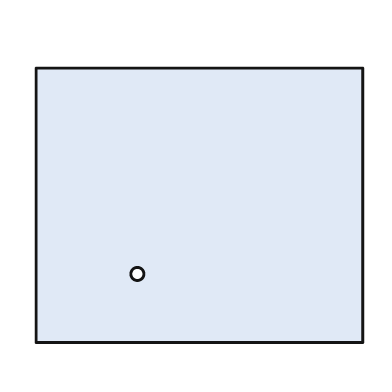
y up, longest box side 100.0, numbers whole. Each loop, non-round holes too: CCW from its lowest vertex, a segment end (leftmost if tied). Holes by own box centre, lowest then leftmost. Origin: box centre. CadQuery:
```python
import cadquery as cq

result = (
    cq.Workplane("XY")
    .moveTo(-50.0, -42.0)
    .lineTo(50.0, -42.0)
    .lineTo(50.0, 42.0)
    .lineTo(-50.0, 42.0)
    .close()
    .moveTo(-19.0, -21.0)
    .circle(2.0)
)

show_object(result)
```